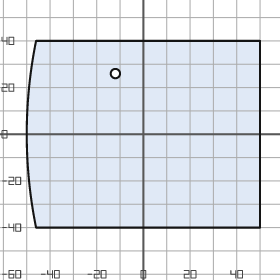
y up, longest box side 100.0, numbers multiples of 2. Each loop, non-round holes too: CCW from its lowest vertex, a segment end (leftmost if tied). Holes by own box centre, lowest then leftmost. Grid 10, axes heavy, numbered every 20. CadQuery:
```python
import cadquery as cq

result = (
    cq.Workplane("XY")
    .moveTo(-46.0, -40.0)
    .lineTo(50.0, -40.0)
    .lineTo(50.0, 40.0)
    .lineTo(-46.0, 40.0)
    .threePointArc((-50.0, 0.0), (-46.0, -40.0))
    .close()
    .moveTo(-12.0, 26.0)
    .circle(2.0)
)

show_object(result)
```